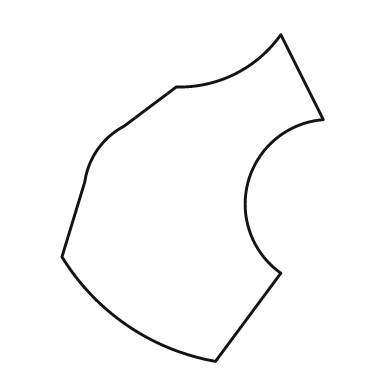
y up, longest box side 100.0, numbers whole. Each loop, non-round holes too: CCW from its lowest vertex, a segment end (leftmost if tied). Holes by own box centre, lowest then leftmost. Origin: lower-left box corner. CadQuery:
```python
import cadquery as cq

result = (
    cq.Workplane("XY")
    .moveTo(47.0, 0.0)
    .lineTo(67.0, 27.0)
    .threePointArc((57.0, 55.0), (80.0, 74.0))
    .lineTo(67.0, 100.0)
    .threePointArc((53.0, 88.0), (35.0, 84.0))
    .lineTo(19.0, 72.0)
    .threePointArc((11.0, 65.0), (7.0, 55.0))
    .lineTo(0.0, 32.0)
    .threePointArc((20.0, 11.0), (47.0, 0.0))
    .close()
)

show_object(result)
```